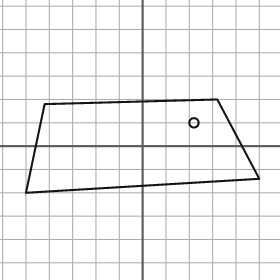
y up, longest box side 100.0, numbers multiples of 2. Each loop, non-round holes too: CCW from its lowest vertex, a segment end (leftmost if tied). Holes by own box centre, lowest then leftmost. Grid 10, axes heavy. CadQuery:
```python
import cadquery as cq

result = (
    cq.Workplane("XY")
    .moveTo(-50.0, -20.0)
    .lineTo(50.0, -14.0)
    .lineTo(32.0, 20.0)
    .lineTo(-42.0, 18.0)
    .close()
    .moveTo(22.0, 10.0)
    .circle(2.0)
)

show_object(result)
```